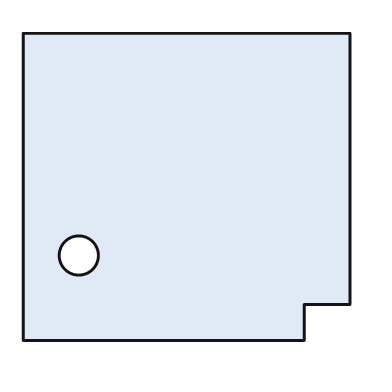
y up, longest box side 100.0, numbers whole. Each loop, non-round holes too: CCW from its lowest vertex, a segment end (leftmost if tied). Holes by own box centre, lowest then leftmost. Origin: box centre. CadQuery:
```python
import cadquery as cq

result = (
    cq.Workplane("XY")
    .moveTo(-50.0, -47.0)
    .lineTo(36.0, -47.0)
    .lineTo(36.0, -36.0)
    .lineTo(50.0, -36.0)
    .lineTo(50.0, 47.0)
    .lineTo(-50.0, 47.0)
    .close()
    .moveTo(-33.0, -21.0)
    .circle(6.0)
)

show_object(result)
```